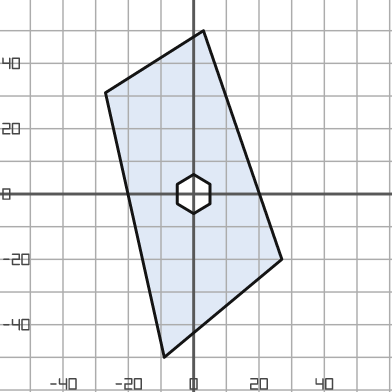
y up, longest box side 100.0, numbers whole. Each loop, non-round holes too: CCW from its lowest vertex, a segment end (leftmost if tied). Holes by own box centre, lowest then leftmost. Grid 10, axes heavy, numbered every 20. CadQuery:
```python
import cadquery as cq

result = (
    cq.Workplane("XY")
    .moveTo(-9.0, -50.0)
    .lineTo(27.0, -20.0)
    .lineTo(3.0, 50.0)
    .lineTo(-27.0, 31.0)
    .close()
    .moveTo(0.0, -6.0)
    .lineTo(5.0, -3.0)
    .lineTo(5.0, 3.0)
    .lineTo(0.0, 6.0)
    .lineTo(-5.0, 3.0)
    .lineTo(-5.0, -3.0)
    .close()
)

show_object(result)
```